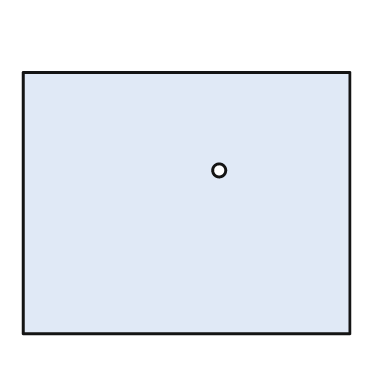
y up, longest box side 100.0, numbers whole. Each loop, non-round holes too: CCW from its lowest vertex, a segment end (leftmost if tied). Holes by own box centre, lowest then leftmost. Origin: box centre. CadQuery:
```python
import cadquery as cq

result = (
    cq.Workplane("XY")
    .moveTo(-50.0, -40.0)
    .lineTo(50.0, -40.0)
    .lineTo(50.0, 40.0)
    .lineTo(-50.0, 40.0)
    .close()
    .moveTo(10.0, 10.0)
    .circle(2.0)
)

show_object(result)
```